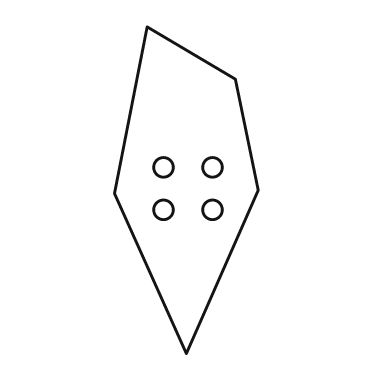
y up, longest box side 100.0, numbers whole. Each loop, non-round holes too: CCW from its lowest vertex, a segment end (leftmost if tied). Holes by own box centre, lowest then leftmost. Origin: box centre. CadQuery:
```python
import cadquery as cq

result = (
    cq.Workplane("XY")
    .moveTo(0.0, -50.0)
    .lineTo(22.0, 0.0)
    .lineTo(15.0, 34.0)
    .lineTo(-12.0, 50.0)
    .lineTo(-22.0, -1.0)
    .close()
    .moveTo(-7.0, -6.0)
    .circle(3.0)
    .moveTo(8.0, -6.0)
    .circle(3.0)
    .moveTo(-7.0, 7.0)
    .circle(3.0)
    .moveTo(8.0, 7.0)
    .circle(3.0)
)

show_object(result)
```